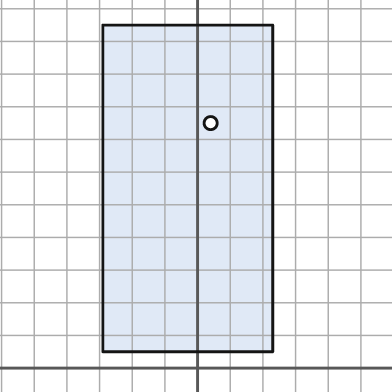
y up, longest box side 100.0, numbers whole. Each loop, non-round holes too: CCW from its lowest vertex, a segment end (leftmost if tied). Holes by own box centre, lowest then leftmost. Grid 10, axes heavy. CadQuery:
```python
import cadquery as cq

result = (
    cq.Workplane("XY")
    .moveTo(-29.0, 5.0)
    .lineTo(23.0, 5.0)
    .lineTo(23.0, 105.0)
    .lineTo(-29.0, 105.0)
    .close()
    .moveTo(4.0, 75.0)
    .circle(2.0)
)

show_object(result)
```